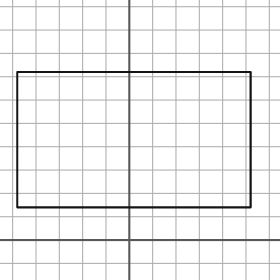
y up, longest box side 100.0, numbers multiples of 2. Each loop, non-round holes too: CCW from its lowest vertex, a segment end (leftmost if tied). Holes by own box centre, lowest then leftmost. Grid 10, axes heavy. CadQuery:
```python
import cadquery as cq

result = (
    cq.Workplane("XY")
    .moveTo(-48.0, 14.0)
    .lineTo(52.0, 14.0)
    .lineTo(52.0, 72.0)
    .lineTo(-48.0, 72.0)
    .close()
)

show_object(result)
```